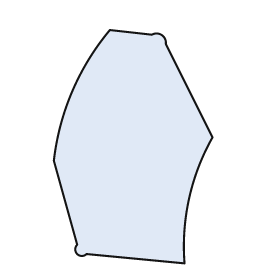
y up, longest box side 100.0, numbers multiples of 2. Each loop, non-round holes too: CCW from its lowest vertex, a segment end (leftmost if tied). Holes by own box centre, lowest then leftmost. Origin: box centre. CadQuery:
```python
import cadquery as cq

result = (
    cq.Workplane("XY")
    .moveTo(22.0, -50.0)
    .threePointArc((24.0, -22.0), (34.0, 4.0))
    .lineTo(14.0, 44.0)
    .threePointArc((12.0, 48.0), (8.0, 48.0))
    .lineTo(-10.0, 50.0)
    .threePointArc((-26.0, 24.0), (-34.0, -6.0))
    .lineTo(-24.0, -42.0)
    .threePointArc((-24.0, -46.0), (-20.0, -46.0))
    .close()
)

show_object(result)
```